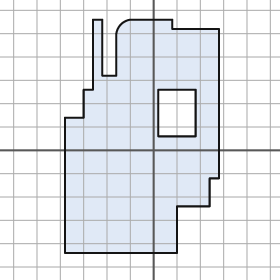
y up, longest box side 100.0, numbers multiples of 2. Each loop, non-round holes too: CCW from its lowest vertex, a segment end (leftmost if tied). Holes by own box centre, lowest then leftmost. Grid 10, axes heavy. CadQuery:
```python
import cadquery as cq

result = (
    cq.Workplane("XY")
    .moveTo(-38.0, -44.0)
    .lineTo(10.0, -44.0)
    .lineTo(10.0, -24.0)
    .lineTo(24.0, -24.0)
    .lineTo(24.0, -12.0)
    .lineTo(28.0, -12.0)
    .lineTo(28.0, 52.0)
    .lineTo(8.0, 52.0)
    .lineTo(8.0, 56.0)
    .lineTo(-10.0, 56.0)
    .threePointArc((-14.0, 54.0), (-16.0, 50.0))
    .lineTo(-16.0, 32.0)
    .lineTo(-22.0, 32.0)
    .lineTo(-22.0, 56.0)
    .lineTo(-26.0, 56.0)
    .lineTo(-26.0, 26.0)
    .lineTo(-30.0, 26.0)
    .lineTo(-30.0, 14.0)
    .lineTo(-38.0, 14.0)
    .close()
    .moveTo(2.0, 6.0)
    .lineTo(18.0, 6.0)
    .lineTo(18.0, 26.0)
    .lineTo(2.0, 26.0)
    .close()
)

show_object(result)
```